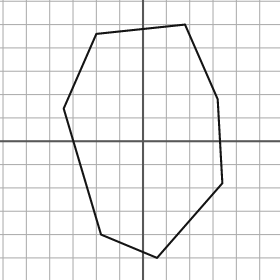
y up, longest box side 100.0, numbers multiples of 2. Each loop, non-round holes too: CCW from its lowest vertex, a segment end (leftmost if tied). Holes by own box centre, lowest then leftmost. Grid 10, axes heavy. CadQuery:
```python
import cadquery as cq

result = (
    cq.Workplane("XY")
    .moveTo(6.0, -50.0)
    .lineTo(34.0, -18.0)
    .lineTo(32.0, 18.0)
    .lineTo(18.0, 50.0)
    .lineTo(-20.0, 46.0)
    .lineTo(-34.0, 14.0)
    .lineTo(-18.0, -40.0)
    .close()
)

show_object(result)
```